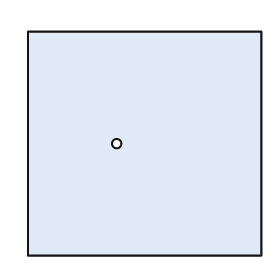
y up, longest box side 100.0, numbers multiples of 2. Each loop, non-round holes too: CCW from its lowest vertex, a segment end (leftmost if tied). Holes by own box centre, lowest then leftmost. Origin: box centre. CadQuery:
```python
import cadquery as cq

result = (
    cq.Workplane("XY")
    .moveTo(-50.0, -48.0)
    .lineTo(50.0, -48.0)
    .lineTo(50.0, 48.0)
    .lineTo(-50.0, 48.0)
    .close()
    .moveTo(-12.0, 0.0)
    .circle(2.0)
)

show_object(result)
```